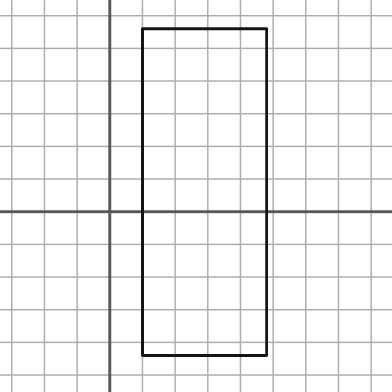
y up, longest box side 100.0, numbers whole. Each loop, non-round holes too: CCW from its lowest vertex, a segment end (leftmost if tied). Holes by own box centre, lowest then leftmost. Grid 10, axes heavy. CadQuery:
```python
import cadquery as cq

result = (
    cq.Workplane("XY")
    .moveTo(10.0, -44.0)
    .lineTo(48.0, -44.0)
    .lineTo(48.0, 56.0)
    .lineTo(10.0, 56.0)
    .close()
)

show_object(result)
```